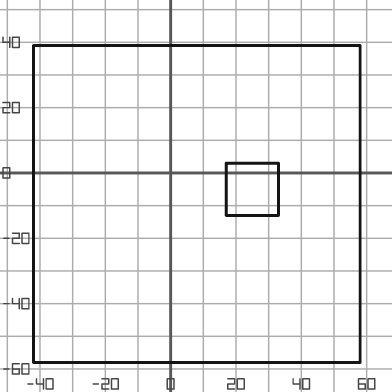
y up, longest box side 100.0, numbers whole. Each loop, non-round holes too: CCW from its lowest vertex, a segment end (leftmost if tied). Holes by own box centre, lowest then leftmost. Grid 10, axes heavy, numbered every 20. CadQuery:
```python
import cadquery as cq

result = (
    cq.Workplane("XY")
    .moveTo(-42.0, -58.0)
    .lineTo(58.0, -58.0)
    .lineTo(58.0, 39.0)
    .lineTo(-42.0, 39.0)
    .close()
    .moveTo(17.0, -13.0)
    .lineTo(33.0, -13.0)
    .lineTo(33.0, 3.0)
    .lineTo(17.0, 3.0)
    .close()
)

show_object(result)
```